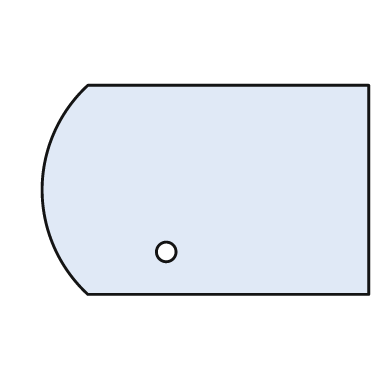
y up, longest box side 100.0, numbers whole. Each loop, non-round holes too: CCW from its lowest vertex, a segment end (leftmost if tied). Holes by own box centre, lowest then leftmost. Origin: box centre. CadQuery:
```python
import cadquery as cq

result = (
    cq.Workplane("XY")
    .moveTo(-36.0, -32.0)
    .lineTo(50.0, -32.0)
    .lineTo(50.0, 32.0)
    .lineTo(-36.0, 32.0)
    .threePointArc((-50.0, 0.0), (-36.0, -32.0))
    .close()
    .moveTo(-12.0, -19.0)
    .circle(3.0)
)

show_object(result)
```